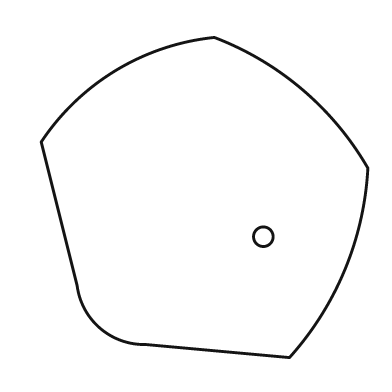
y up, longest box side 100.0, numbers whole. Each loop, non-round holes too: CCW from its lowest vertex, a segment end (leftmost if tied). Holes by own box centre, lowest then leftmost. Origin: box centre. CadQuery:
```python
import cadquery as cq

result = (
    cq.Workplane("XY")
    .moveTo(26.0, -49.0)
    .threePointArc((43.0, -22.0), (50.0, 9.0))
    .threePointArc((30.0, 33.0), (3.0, 49.0))
    .threePointArc((-27.0, 39.0), (-50.0, 17.0))
    .lineTo(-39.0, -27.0)
    .threePointArc((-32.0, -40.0), (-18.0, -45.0))
    .close()
    .moveTo(18.0, -12.0)
    .circle(3.0)
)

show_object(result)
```